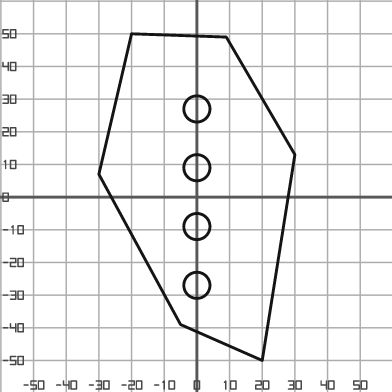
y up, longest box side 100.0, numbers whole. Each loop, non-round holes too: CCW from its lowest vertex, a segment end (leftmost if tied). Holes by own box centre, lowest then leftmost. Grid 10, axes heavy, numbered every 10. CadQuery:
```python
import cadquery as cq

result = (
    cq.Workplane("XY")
    .moveTo(20.0, -50.0)
    .lineTo(30.0, 13.0)
    .lineTo(9.0, 49.0)
    .lineTo(-20.0, 50.0)
    .lineTo(-30.0, 7.0)
    .lineTo(-5.0, -39.0)
    .close()
    .moveTo(0.0, -27.0)
    .circle(4.0)
    .moveTo(0.0, -9.0)
    .circle(4.0)
    .moveTo(0.0, 9.0)
    .circle(4.0)
    .moveTo(0.0, 27.0)
    .circle(4.0)
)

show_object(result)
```